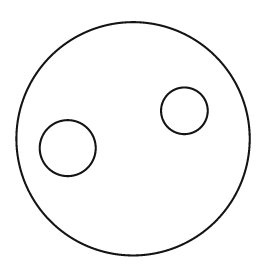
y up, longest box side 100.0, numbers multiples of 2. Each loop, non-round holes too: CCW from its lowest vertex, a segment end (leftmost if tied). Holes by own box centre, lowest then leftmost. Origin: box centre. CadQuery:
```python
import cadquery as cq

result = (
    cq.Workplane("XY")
    .moveTo(0.0, 0.0)
    .circle(50.0)
    .moveTo(-28.0, -4.0)
    .circle(12.0)
    .moveTo(22.0, 12.0)
    .circle(10.0)
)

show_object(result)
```